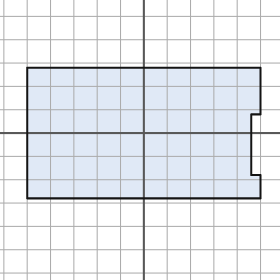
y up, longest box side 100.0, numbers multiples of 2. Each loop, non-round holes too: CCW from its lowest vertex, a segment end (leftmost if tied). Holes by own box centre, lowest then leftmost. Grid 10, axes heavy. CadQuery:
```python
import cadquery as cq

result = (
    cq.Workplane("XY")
    .moveTo(-50.0, -28.0)
    .lineTo(50.0, -28.0)
    .lineTo(50.0, -18.0)
    .lineTo(46.0, -18.0)
    .lineTo(46.0, 8.0)
    .lineTo(50.0, 8.0)
    .lineTo(50.0, 28.0)
    .lineTo(-50.0, 28.0)
    .close()
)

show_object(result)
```